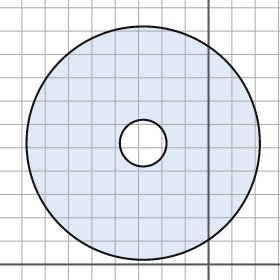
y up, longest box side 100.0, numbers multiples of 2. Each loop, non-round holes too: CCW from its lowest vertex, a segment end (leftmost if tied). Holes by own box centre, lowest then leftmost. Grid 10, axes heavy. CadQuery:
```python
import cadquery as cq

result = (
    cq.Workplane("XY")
    .moveTo(-28.0, 52.0)
    .circle(50.0)
    .moveTo(-28.0, 52.0)
    .circle(10.0)
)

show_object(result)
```